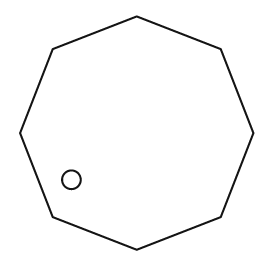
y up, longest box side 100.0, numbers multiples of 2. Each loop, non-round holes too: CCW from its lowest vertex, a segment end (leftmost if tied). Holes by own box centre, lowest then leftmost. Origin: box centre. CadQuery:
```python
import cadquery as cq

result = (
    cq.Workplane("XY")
    .moveTo(0.0, -50.0)
    .lineTo(36.0, -36.0)
    .lineTo(50.0, 0.0)
    .lineTo(36.0, 36.0)
    .lineTo(0.0, 50.0)
    .lineTo(-36.0, 36.0)
    .lineTo(-50.0, 0.0)
    .lineTo(-36.0, -36.0)
    .close()
    .moveTo(-28.0, -20.0)
    .circle(4.0)
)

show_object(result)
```